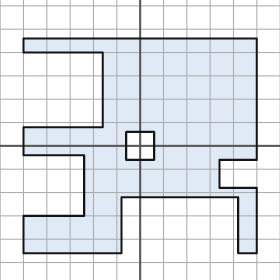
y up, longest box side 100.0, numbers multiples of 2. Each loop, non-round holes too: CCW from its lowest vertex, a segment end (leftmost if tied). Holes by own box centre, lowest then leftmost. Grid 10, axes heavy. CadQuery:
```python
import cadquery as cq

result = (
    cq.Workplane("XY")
    .moveTo(-50.0, -46.0)
    .lineTo(-8.0, -46.0)
    .lineTo(-8.0, -22.0)
    .lineTo(42.0, -22.0)
    .lineTo(42.0, -46.0)
    .lineTo(50.0, -46.0)
    .lineTo(50.0, -18.0)
    .lineTo(34.0, -18.0)
    .lineTo(34.0, -6.0)
    .lineTo(50.0, -6.0)
    .lineTo(50.0, 46.0)
    .lineTo(-50.0, 46.0)
    .lineTo(-50.0, 40.0)
    .lineTo(-16.0, 40.0)
    .lineTo(-16.0, 8.0)
    .lineTo(-50.0, 8.0)
    .lineTo(-50.0, -4.0)
    .lineTo(-24.0, -4.0)
    .lineTo(-24.0, -30.0)
    .lineTo(-50.0, -30.0)
    .close()
    .moveTo(-6.0, -6.0)
    .lineTo(6.0, -6.0)
    .lineTo(6.0, 6.0)
    .lineTo(-6.0, 6.0)
    .close()
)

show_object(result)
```